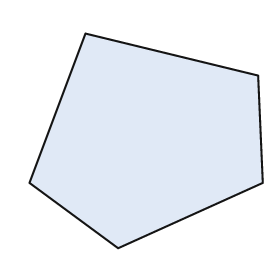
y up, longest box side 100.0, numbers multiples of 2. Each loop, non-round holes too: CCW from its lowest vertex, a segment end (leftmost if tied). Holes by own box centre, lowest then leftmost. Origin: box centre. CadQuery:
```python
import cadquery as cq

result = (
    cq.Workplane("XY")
    .moveTo(-12.0, -46.0)
    .lineTo(50.0, -18.0)
    .lineTo(48.0, 28.0)
    .lineTo(-26.0, 46.0)
    .lineTo(-50.0, -18.0)
    .close()
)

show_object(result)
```